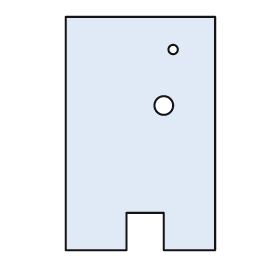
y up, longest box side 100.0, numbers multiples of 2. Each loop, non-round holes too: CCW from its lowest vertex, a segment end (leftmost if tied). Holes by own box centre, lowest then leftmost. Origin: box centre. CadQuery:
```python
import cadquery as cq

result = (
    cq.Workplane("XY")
    .moveTo(-32.0, -50.0)
    .lineTo(-6.0, -50.0)
    .lineTo(-6.0, -34.0)
    .lineTo(10.0, -34.0)
    .lineTo(10.0, -50.0)
    .lineTo(32.0, -50.0)
    .lineTo(32.0, 50.0)
    .lineTo(-32.0, 50.0)
    .close()
    .moveTo(10.0, 12.0)
    .circle(4.0)
    .moveTo(14.0, 36.0)
    .circle(2.0)
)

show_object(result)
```